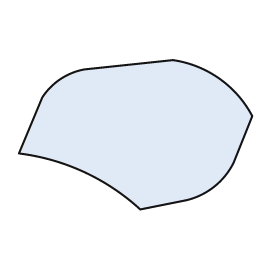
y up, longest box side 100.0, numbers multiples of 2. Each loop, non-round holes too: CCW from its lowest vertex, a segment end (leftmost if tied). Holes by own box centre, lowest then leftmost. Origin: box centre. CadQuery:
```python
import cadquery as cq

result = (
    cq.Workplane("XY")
    .moveTo(2.0, -32.0)
    .lineTo(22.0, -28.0)
    .threePointArc((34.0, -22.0), (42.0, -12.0))
    .lineTo(50.0, 8.0)
    .threePointArc((36.0, 24.0), (16.0, 32.0))
    .lineTo(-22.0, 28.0)
    .threePointArc((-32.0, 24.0), (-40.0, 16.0))
    .lineTo(-50.0, -8.0)
    .threePointArc((-22.0, -16.0), (2.0, -32.0))
    .close()
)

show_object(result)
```